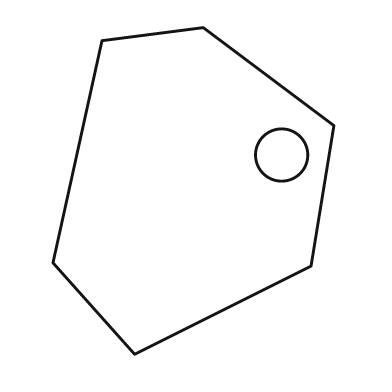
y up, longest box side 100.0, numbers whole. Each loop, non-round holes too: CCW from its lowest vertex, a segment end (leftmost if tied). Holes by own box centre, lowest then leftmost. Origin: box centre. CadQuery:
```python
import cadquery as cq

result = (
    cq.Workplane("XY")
    .moveTo(-18.0, -50.0)
    .lineTo(36.0, -23.0)
    .lineTo(43.0, 20.0)
    .lineTo(3.0, 50.0)
    .lineTo(-28.0, 46.0)
    .lineTo(-43.0, -22.0)
    .close()
    .moveTo(27.0, 11.0)
    .circle(8.0)
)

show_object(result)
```